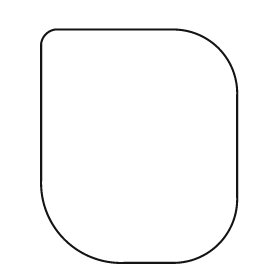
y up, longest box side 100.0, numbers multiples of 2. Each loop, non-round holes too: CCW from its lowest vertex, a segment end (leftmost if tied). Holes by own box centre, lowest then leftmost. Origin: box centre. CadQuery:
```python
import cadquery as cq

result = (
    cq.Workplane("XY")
    .moveTo(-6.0, -50.0)
    .lineTo(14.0, -50.0)
    .threePointArc((34.0, -42.0), (42.0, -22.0))
    .lineTo(42.0, 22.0)
    .threePointArc((34.0, 42.0), (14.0, 50.0))
    .lineTo(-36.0, 50.0)
    .threePointArc((-40.0, 48.0), (-42.0, 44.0))
    .lineTo(-42.0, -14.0)
    .threePointArc((-32.0, -40.0), (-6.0, -50.0))
    .close()
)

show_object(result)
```